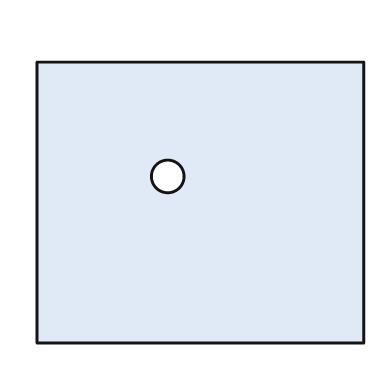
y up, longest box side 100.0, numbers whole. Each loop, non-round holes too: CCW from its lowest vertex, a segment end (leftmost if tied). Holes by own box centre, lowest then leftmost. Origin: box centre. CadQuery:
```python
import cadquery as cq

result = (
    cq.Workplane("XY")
    .moveTo(-50.0, -43.0)
    .lineTo(50.0, -43.0)
    .lineTo(50.0, 43.0)
    .lineTo(-50.0, 43.0)
    .close()
    .moveTo(-10.0, 8.0)
    .circle(5.0)
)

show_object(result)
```